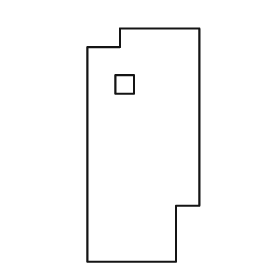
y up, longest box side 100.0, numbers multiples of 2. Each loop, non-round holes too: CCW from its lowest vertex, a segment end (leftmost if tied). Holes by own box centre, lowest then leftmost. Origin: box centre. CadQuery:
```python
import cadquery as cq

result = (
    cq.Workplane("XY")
    .moveTo(-24.0, -50.0)
    .lineTo(14.0, -50.0)
    .lineTo(14.0, -26.0)
    .lineTo(24.0, -26.0)
    .lineTo(24.0, 50.0)
    .lineTo(-10.0, 50.0)
    .lineTo(-10.0, 42.0)
    .lineTo(-24.0, 42.0)
    .close()
    .moveTo(-12.0, 22.0)
    .lineTo(-4.0, 22.0)
    .lineTo(-4.0, 30.0)
    .lineTo(-12.0, 30.0)
    .close()
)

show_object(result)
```